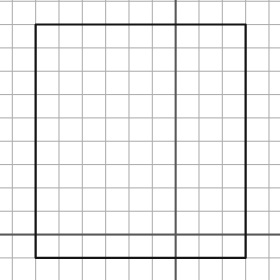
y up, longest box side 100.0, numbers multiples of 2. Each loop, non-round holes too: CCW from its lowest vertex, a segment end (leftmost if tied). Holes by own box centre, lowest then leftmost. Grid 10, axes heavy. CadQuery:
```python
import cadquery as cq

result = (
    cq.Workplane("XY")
    .moveTo(-60.0, -10.0)
    .lineTo(30.0, -10.0)
    .lineTo(30.0, 90.0)
    .lineTo(-60.0, 90.0)
    .close()
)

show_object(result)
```